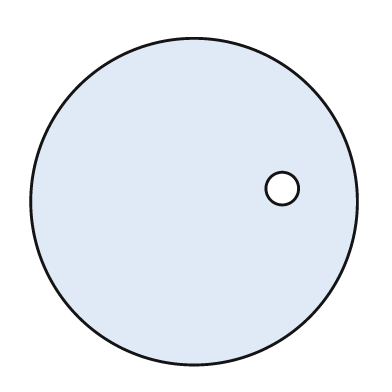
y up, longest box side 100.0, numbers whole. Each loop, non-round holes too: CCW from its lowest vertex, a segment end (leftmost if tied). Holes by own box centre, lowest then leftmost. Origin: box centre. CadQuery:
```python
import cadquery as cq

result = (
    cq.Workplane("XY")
    .moveTo(0.0, 0.0)
    .circle(50.0)
    .moveTo(27.0, 4.0)
    .circle(5.0)
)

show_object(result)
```